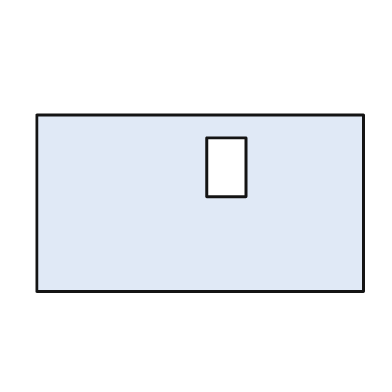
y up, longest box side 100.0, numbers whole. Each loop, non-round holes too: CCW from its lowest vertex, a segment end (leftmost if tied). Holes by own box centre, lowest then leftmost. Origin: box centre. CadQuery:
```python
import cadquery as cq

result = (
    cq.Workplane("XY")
    .moveTo(-50.0, -27.0)
    .lineTo(50.0, -27.0)
    .lineTo(50.0, 27.0)
    .lineTo(-50.0, 27.0)
    .close()
    .moveTo(2.0, 2.0)
    .lineTo(14.0, 2.0)
    .lineTo(14.0, 20.0)
    .lineTo(2.0, 20.0)
    .close()
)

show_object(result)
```